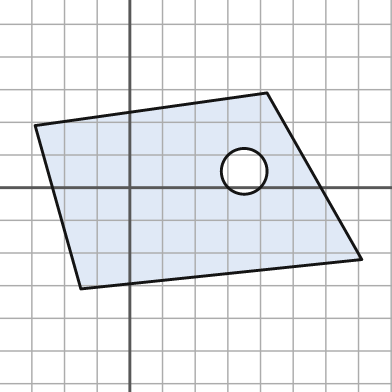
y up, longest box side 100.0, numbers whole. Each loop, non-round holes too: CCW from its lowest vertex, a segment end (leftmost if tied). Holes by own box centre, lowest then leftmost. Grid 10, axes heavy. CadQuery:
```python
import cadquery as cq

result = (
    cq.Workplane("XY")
    .moveTo(-15.0, -31.0)
    .lineTo(71.0, -22.0)
    .lineTo(42.0, 29.0)
    .lineTo(-29.0, 19.0)
    .close()
    .moveTo(35.0, 5.0)
    .circle(7.0)
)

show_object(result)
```